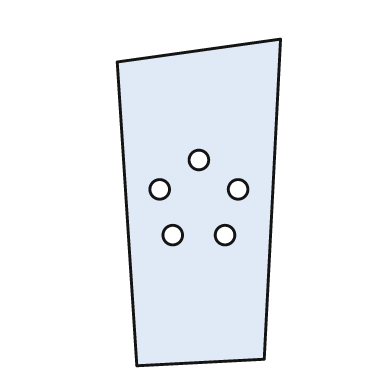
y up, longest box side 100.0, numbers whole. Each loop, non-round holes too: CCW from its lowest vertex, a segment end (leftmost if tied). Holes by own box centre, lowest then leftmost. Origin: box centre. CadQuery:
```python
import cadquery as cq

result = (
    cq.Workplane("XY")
    .moveTo(-19.0, -50.0)
    .lineTo(20.0, -48.0)
    .lineTo(25.0, 50.0)
    .lineTo(-25.0, 43.0)
    .close()
    .moveTo(-8.0, -10.0)
    .circle(3.0)
    .moveTo(8.0, -10.0)
    .circle(3.0)
    .moveTo(-12.0, 4.0)
    .circle(3.0)
    .moveTo(12.0, 4.0)
    .circle(3.0)
    .moveTo(0.0, 13.0)
    .circle(3.0)
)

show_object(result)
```